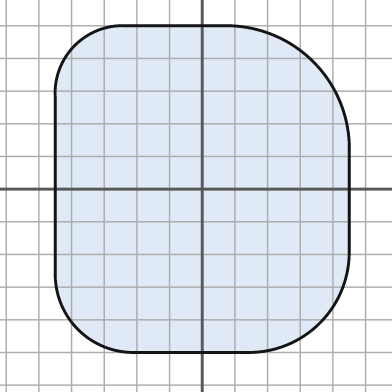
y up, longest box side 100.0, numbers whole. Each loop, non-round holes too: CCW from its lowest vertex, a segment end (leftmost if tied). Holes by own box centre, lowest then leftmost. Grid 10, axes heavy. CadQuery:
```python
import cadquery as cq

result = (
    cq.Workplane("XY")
    .moveTo(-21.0, -50.0)
    .lineTo(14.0, -50.0)
    .threePointArc((36.0, -41.0), (45.0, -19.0))
    .lineTo(45.0, 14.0)
    .threePointArc((34.0, 39.0), (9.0, 50.0))
    .lineTo(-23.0, 50.0)
    .threePointArc((-39.0, 44.0), (-45.0, 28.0))
    .lineTo(-45.0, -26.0)
    .threePointArc((-38.0, -43.0), (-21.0, -50.0))
    .close()
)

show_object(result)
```